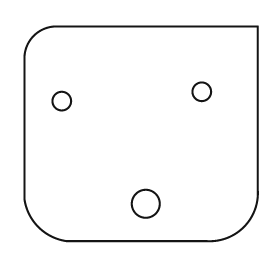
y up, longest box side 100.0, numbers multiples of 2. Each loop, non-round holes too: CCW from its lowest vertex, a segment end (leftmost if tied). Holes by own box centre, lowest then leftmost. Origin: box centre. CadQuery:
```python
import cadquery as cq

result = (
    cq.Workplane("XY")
    .moveTo(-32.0, -46.0)
    .lineTo(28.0, -46.0)
    .threePointArc((44.0, -40.0), (50.0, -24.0))
    .lineTo(50.0, 46.0)
    .lineTo(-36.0, 46.0)
    .threePointArc((-46.0, 42.0), (-50.0, 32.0))
    .lineTo(-50.0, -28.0)
    .threePointArc((-44.0, -40.0), (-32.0, -46.0))
    .close()
    .moveTo(2.0, -30.0)
    .circle(6.0)
    .moveTo(-34.0, 14.0)
    .circle(4.0)
    .moveTo(26.0, 18.0)
    .circle(4.0)
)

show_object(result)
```